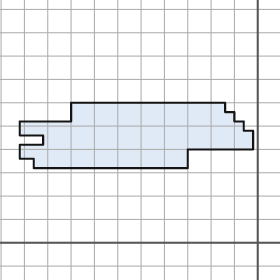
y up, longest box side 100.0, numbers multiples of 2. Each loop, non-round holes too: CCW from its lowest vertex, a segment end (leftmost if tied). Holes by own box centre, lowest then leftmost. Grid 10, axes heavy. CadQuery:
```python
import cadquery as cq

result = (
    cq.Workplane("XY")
    .moveTo(-96.0, 32.0)
    .lineTo(-30.0, 32.0)
    .lineTo(-30.0, 40.0)
    .lineTo(-2.0, 40.0)
    .lineTo(-2.0, 48.0)
    .lineTo(-6.0, 48.0)
    .lineTo(-6.0, 52.0)
    .lineTo(-10.0, 52.0)
    .lineTo(-10.0, 56.0)
    .lineTo(-14.0, 56.0)
    .lineTo(-14.0, 60.0)
    .lineTo(-80.0, 60.0)
    .lineTo(-80.0, 52.0)
    .lineTo(-102.0, 52.0)
    .lineTo(-102.0, 46.0)
    .lineTo(-92.0, 46.0)
    .lineTo(-92.0, 42.0)
    .lineTo(-102.0, 42.0)
    .lineTo(-102.0, 36.0)
    .lineTo(-96.0, 36.0)
    .close()
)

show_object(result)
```